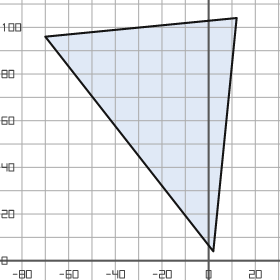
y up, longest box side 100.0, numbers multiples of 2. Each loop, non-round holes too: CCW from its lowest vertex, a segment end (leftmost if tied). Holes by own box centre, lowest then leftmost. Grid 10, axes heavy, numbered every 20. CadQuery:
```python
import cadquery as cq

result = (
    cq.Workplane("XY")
    .moveTo(2.0, 4.0)
    .lineTo(12.0, 104.0)
    .lineTo(-70.0, 96.0)
    .close()
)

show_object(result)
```